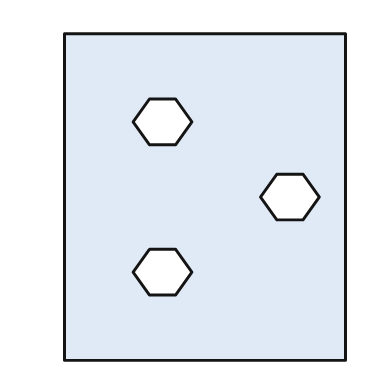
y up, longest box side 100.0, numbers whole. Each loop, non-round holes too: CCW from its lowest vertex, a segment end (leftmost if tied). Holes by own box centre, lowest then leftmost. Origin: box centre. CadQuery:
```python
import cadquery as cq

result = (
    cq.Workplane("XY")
    .moveTo(-43.0, -50.0)
    .lineTo(43.0, -50.0)
    .lineTo(43.0, 50.0)
    .lineTo(-43.0, 50.0)
    .close()
    .moveTo(-17.0, -30.0)
    .lineTo(-9.0, -30.0)
    .lineTo(-4.0, -23.0)
    .lineTo(-9.0, -16.0)
    .lineTo(-17.0, -16.0)
    .lineTo(-22.0, -23.0)
    .close()
    .moveTo(22.0, -7.0)
    .lineTo(30.0, -7.0)
    .lineTo(35.0, 0.0)
    .lineTo(30.0, 7.0)
    .lineTo(22.0, 7.0)
    .lineTo(17.0, 0.0)
    .close()
    .moveTo(-17.0, 16.0)
    .lineTo(-9.0, 16.0)
    .lineTo(-4.0, 23.0)
    .lineTo(-9.0, 30.0)
    .lineTo(-17.0, 30.0)
    .lineTo(-22.0, 23.0)
    .close()
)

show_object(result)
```